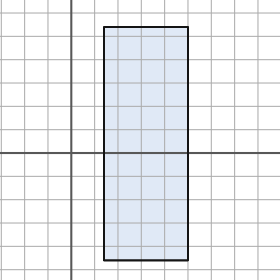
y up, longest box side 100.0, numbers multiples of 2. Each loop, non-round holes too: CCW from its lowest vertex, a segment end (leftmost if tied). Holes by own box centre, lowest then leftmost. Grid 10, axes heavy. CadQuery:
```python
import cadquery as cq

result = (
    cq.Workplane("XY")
    .moveTo(14.0, -46.0)
    .lineTo(50.0, -46.0)
    .lineTo(50.0, 54.0)
    .lineTo(14.0, 54.0)
    .close()
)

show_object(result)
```